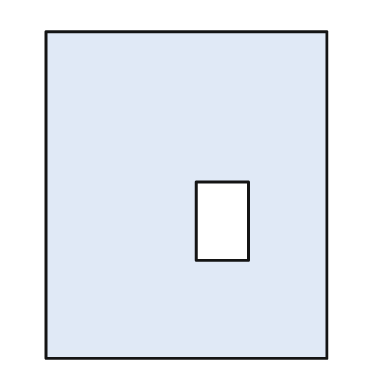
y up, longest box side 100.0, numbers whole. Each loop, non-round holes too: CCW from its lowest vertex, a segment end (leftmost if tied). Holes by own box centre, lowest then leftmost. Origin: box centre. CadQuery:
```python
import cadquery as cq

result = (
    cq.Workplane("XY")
    .moveTo(-43.0, -50.0)
    .lineTo(43.0, -50.0)
    .lineTo(43.0, 50.0)
    .lineTo(-43.0, 50.0)
    .close()
    .moveTo(3.0, -20.0)
    .lineTo(19.0, -20.0)
    .lineTo(19.0, 4.0)
    .lineTo(3.0, 4.0)
    .close()
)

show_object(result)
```